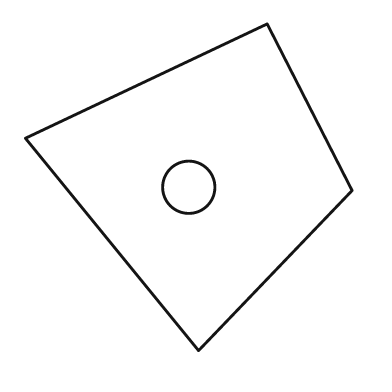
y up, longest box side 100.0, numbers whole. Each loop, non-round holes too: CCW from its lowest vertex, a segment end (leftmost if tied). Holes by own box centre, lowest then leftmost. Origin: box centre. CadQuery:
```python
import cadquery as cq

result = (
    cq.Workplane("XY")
    .moveTo(3.0, -50.0)
    .lineTo(50.0, -1.0)
    .lineTo(24.0, 50.0)
    .lineTo(-50.0, 15.0)
    .close()
    .moveTo(0.0, 0.0)
    .circle(8.0)
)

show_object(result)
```